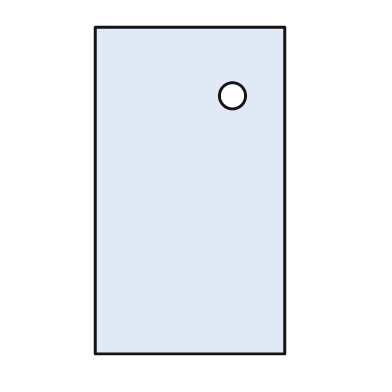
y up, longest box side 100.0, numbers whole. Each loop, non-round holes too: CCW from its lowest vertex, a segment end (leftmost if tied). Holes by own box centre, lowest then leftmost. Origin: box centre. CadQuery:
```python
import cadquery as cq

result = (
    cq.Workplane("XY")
    .moveTo(-29.0, -50.0)
    .lineTo(29.0, -50.0)
    .lineTo(29.0, 50.0)
    .lineTo(-29.0, 50.0)
    .close()
    .moveTo(13.0, 29.0)
    .circle(4.0)
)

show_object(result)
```